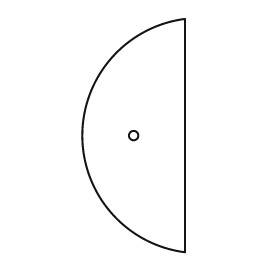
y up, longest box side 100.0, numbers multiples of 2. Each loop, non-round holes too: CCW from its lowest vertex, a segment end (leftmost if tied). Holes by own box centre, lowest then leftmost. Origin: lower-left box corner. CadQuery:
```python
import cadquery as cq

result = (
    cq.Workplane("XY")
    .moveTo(44.0, 0.0)
    .lineTo(44.0, 100.0)
    .threePointArc((0.0, 50.0), (44.0, 0.0))
    .close()
    .moveTo(22.0, 50.0)
    .circle(2.0)
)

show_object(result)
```